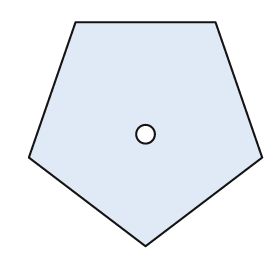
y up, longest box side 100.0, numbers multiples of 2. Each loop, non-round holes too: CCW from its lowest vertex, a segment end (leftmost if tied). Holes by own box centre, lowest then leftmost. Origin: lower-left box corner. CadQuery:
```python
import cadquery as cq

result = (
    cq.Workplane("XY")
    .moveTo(50.0, 0.0)
    .lineTo(100.0, 38.0)
    .lineTo(80.0, 96.0)
    .lineTo(20.0, 96.0)
    .lineTo(0.0, 38.0)
    .close()
    .moveTo(50.0, 48.0)
    .circle(4.0)
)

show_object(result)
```